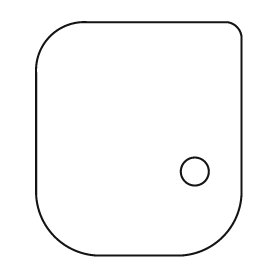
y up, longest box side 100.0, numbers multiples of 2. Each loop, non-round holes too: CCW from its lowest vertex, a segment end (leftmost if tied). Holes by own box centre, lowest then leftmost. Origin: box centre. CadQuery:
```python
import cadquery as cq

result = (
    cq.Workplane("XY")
    .moveTo(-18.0, -50.0)
    .lineTo(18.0, -50.0)
    .threePointArc((36.0, -42.0), (44.0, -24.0))
    .lineTo(44.0, 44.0)
    .threePointArc((42.0, 48.0), (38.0, 50.0))
    .lineTo(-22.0, 50.0)
    .threePointArc((-38.0, 44.0), (-44.0, 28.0))
    .lineTo(-44.0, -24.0)
    .threePointArc((-36.0, -42.0), (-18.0, -50.0))
    .close()
    .moveTo(24.0, -14.0)
    .circle(6.0)
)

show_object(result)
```